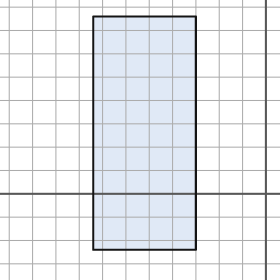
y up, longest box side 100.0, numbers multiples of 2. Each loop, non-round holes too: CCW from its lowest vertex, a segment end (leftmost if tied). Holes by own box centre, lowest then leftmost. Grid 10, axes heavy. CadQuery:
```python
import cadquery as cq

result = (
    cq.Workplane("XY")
    .moveTo(-74.0, -24.0)
    .lineTo(-30.0, -24.0)
    .lineTo(-30.0, 76.0)
    .lineTo(-74.0, 76.0)
    .close()
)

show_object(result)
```